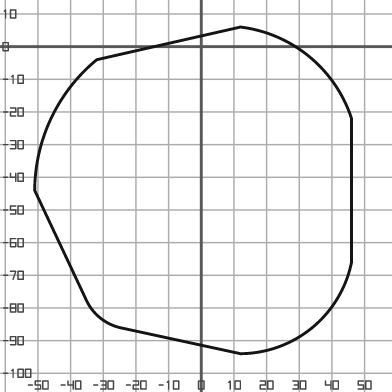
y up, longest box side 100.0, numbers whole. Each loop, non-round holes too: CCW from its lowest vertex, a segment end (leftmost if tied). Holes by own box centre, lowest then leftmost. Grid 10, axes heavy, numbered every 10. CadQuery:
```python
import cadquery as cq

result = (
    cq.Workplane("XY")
    .moveTo(12.0, -94.0)
    .threePointArc((34.0, -86.0), (46.0, -66.0))
    .lineTo(46.0, -22.0)
    .threePointArc((33.0, -3.0), (12.0, 6.0))
    .lineTo(-32.0, -4.0)
    .threePointArc((-46.0, -22.0), (-51.0, -44.0))
    .lineTo(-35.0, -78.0)
    .threePointArc((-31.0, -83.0), (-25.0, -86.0))
    .close()
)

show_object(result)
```